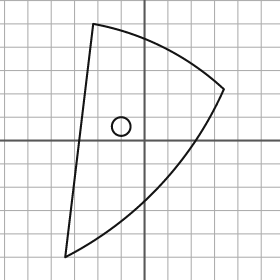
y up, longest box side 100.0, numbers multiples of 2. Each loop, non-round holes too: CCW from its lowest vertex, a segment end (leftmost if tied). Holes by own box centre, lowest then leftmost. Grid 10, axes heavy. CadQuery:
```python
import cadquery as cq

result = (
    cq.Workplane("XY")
    .moveTo(-34.0, -50.0)
    .threePointArc((6.0, -20.0), (34.0, 22.0))
    .threePointArc((8.0, 40.0), (-22.0, 50.0))
    .close()
    .moveTo(-10.0, 6.0)
    .circle(4.0)
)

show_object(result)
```